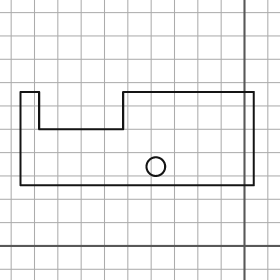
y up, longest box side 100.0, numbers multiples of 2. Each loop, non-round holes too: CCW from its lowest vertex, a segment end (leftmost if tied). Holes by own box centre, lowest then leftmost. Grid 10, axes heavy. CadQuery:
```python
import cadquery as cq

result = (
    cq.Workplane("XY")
    .moveTo(-96.0, 26.0)
    .lineTo(4.0, 26.0)
    .lineTo(4.0, 66.0)
    .lineTo(-52.0, 66.0)
    .lineTo(-52.0, 50.0)
    .lineTo(-88.0, 50.0)
    .lineTo(-88.0, 66.0)
    .lineTo(-96.0, 66.0)
    .close()
    .moveTo(-38.0, 34.0)
    .circle(4.0)
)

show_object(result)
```